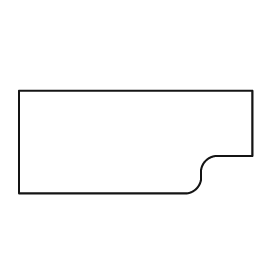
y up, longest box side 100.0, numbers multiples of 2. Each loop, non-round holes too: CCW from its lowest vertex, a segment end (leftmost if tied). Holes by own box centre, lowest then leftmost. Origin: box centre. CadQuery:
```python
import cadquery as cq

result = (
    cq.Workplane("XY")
    .moveTo(-50.0, -22.0)
    .lineTo(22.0, -22.0)
    .threePointArc((26.0, -20.0), (28.0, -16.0))
    .lineTo(28.0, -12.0)
    .threePointArc((30.0, -8.0), (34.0, -6.0))
    .lineTo(50.0, -6.0)
    .lineTo(50.0, 22.0)
    .lineTo(-50.0, 22.0)
    .close()
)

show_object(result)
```